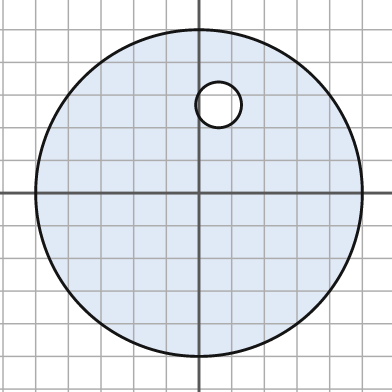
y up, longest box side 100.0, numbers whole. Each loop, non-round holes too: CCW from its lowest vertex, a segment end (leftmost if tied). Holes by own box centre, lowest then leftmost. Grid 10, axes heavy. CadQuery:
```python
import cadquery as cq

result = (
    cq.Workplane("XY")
    .moveTo(0.0, 0.0)
    .circle(50.0)
    .moveTo(6.0, 27.0)
    .circle(7.0)
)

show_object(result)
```